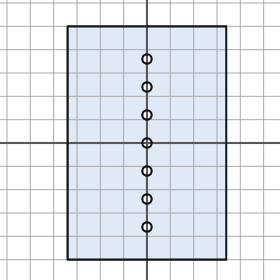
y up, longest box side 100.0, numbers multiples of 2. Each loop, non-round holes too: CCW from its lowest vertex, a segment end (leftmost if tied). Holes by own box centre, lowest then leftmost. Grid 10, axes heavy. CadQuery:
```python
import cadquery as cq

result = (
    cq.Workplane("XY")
    .moveTo(-34.0, -50.0)
    .lineTo(34.0, -50.0)
    .lineTo(34.0, 50.0)
    .lineTo(-34.0, 50.0)
    .close()
    .moveTo(0.0, -36.0)
    .circle(2.0)
    .moveTo(0.0, -24.0)
    .circle(2.0)
    .moveTo(0.0, -12.0)
    .circle(2.0)
    .moveTo(0.0, 0.0)
    .circle(2.0)
    .moveTo(0.0, 12.0)
    .circle(2.0)
    .moveTo(0.0, 24.0)
    .circle(2.0)
    .moveTo(0.0, 36.0)
    .circle(2.0)
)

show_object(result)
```